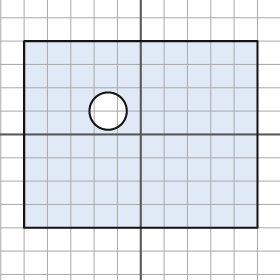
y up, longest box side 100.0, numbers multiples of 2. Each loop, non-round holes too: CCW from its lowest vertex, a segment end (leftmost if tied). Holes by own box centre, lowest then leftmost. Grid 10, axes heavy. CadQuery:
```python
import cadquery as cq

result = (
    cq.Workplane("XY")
    .moveTo(-50.0, -40.0)
    .lineTo(50.0, -40.0)
    .lineTo(50.0, 40.0)
    .lineTo(-50.0, 40.0)
    .close()
    .moveTo(-14.0, 10.0)
    .circle(8.0)
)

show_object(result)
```